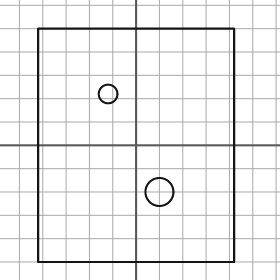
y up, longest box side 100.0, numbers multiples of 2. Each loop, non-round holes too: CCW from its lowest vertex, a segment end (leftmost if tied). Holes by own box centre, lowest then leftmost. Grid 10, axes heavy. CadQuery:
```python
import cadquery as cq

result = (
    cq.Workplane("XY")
    .moveTo(-42.0, -50.0)
    .lineTo(42.0, -50.0)
    .lineTo(42.0, 50.0)
    .lineTo(-42.0, 50.0)
    .close()
    .moveTo(10.0, -20.0)
    .circle(6.0)
    .moveTo(-12.0, 22.0)
    .circle(4.0)
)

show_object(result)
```